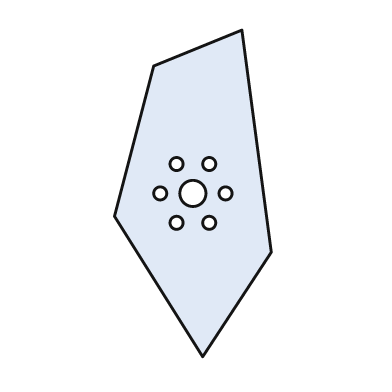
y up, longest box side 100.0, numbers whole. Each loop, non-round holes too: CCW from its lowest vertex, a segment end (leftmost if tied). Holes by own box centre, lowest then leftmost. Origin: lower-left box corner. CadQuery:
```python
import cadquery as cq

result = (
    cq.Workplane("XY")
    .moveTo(27.0, 0.0)
    .lineTo(48.0, 32.0)
    .lineTo(39.0, 100.0)
    .lineTo(12.0, 89.0)
    .lineTo(0.0, 43.0)
    .close()
    .moveTo(19.0, 41.0)
    .circle(2.0)
    .moveTo(29.0, 41.0)
    .circle(2.0)
    .moveTo(14.0, 50.0)
    .circle(2.0)
    .moveTo(24.0, 50.0)
    .circle(4.0)
    .moveTo(34.0, 50.0)
    .circle(2.0)
    .moveTo(19.0, 59.0)
    .circle(2.0)
    .moveTo(29.0, 59.0)
    .circle(2.0)
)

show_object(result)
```